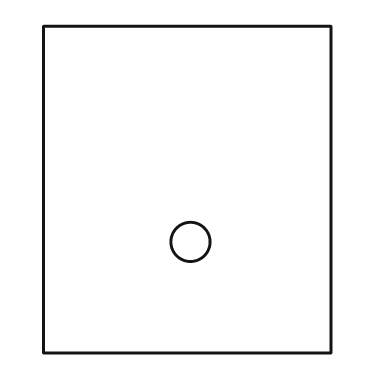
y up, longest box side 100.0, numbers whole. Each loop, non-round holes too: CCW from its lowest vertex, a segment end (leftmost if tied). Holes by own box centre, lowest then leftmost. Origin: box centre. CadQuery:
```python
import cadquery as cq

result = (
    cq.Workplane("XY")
    .moveTo(-44.0, -50.0)
    .lineTo(44.0, -50.0)
    .lineTo(44.0, 50.0)
    .lineTo(-44.0, 50.0)
    .close()
    .moveTo(1.0, -16.0)
    .circle(6.0)
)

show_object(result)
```